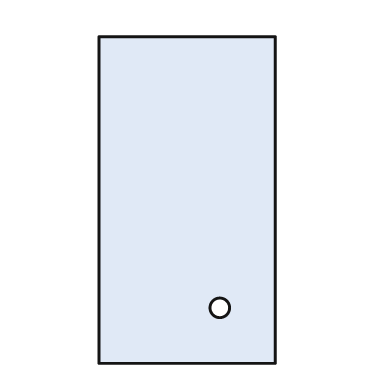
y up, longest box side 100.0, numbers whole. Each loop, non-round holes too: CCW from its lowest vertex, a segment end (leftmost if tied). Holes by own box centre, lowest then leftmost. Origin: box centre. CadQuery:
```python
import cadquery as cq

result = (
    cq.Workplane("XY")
    .moveTo(-27.0, -50.0)
    .lineTo(27.0, -50.0)
    .lineTo(27.0, 50.0)
    .lineTo(-27.0, 50.0)
    .close()
    .moveTo(10.0, -33.0)
    .circle(3.0)
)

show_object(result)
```